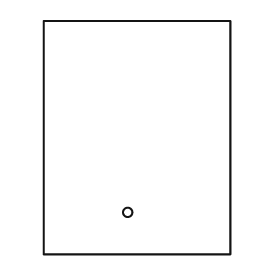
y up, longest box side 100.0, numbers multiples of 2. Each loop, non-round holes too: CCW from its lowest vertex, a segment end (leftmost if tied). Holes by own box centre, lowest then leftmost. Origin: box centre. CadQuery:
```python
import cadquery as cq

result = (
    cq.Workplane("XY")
    .moveTo(-40.0, -50.0)
    .lineTo(40.0, -50.0)
    .lineTo(40.0, 50.0)
    .lineTo(-40.0, 50.0)
    .close()
    .moveTo(-4.0, -32.0)
    .circle(2.0)
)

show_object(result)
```